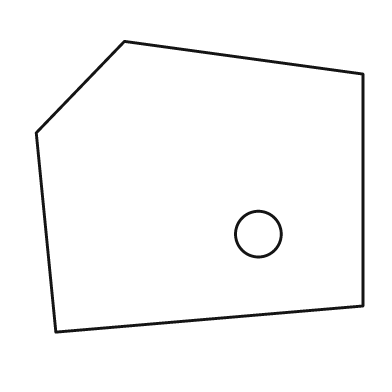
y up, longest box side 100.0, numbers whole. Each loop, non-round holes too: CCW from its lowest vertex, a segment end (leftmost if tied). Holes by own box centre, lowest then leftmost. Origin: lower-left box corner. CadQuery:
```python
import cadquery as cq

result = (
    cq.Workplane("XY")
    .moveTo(6.0, 0.0)
    .lineTo(100.0, 8.0)
    .lineTo(100.0, 79.0)
    .lineTo(27.0, 89.0)
    .lineTo(0.0, 61.0)
    .close()
    .moveTo(68.0, 30.0)
    .circle(7.0)
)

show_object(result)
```